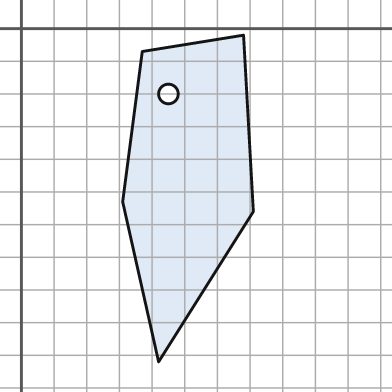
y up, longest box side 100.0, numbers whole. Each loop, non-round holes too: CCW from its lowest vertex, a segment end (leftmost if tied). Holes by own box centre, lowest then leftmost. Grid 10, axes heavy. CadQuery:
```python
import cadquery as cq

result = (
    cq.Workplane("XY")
    .moveTo(42.0, -102.0)
    .lineTo(71.0, -56.0)
    .lineTo(68.0, -2.0)
    .lineTo(37.0, -7.0)
    .lineTo(31.0, -53.0)
    .close()
    .moveTo(45.0, -20.0)
    .circle(3.0)
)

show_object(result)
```